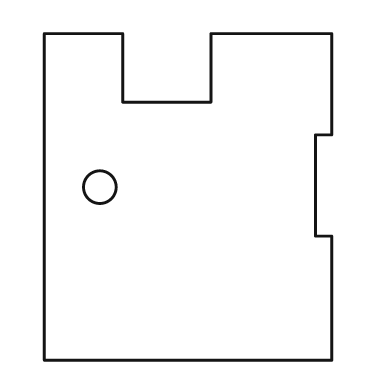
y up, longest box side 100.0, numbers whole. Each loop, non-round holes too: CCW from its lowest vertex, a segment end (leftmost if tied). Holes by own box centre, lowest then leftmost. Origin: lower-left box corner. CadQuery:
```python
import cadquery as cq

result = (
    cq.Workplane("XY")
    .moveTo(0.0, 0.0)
    .lineTo(88.0, 0.0)
    .lineTo(88.0, 38.0)
    .lineTo(83.0, 38.0)
    .lineTo(83.0, 69.0)
    .lineTo(88.0, 69.0)
    .lineTo(88.0, 100.0)
    .lineTo(51.0, 100.0)
    .lineTo(51.0, 79.0)
    .lineTo(24.0, 79.0)
    .lineTo(24.0, 100.0)
    .lineTo(0.0, 100.0)
    .close()
    .moveTo(17.0, 53.0)
    .circle(5.0)
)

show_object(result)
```